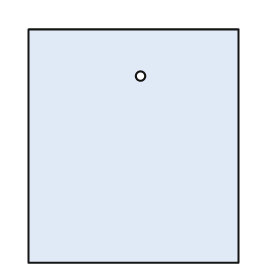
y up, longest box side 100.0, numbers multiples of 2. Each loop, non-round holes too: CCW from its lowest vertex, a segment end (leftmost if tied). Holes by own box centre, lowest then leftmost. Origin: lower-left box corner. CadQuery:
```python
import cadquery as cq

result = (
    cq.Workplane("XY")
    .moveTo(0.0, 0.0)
    .lineTo(90.0, 0.0)
    .lineTo(90.0, 100.0)
    .lineTo(0.0, 100.0)
    .close()
    .moveTo(48.0, 80.0)
    .circle(2.0)
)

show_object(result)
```